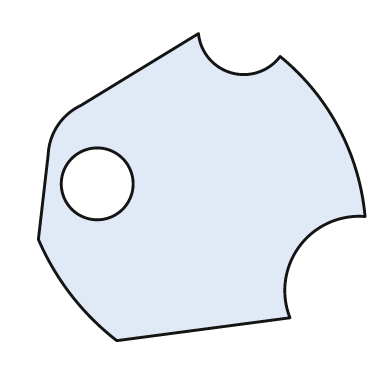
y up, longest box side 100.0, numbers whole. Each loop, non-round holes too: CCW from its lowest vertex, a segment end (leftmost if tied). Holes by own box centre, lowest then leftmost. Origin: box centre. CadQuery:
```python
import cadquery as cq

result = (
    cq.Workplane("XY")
    .moveTo(-26.0, -47.0)
    .lineTo(27.0, -40.0)
    .threePointArc((30.0, -18.0), (50.0, -9.0))
    .threePointArc((42.0, 18.0), (24.0, 40.0))
    .threePointArc((9.0, 35.0), (-1.0, 47.0))
    .lineTo(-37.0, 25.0)
    .threePointArc((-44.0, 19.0), (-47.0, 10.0))
    .lineTo(-50.0, -16.0)
    .threePointArc((-40.0, -33.0), (-26.0, -47.0))
    .close()
    .moveTo(-32.0, 1.0)
    .circle(11.0)
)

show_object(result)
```